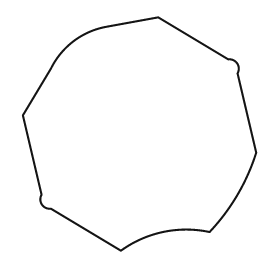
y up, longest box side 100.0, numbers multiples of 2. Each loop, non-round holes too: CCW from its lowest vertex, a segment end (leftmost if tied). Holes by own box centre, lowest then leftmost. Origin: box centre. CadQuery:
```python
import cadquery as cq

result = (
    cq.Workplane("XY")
    .moveTo(-8.0, -50.0)
    .threePointArc((10.0, -42.0), (30.0, -42.0))
    .threePointArc((42.0, -26.0), (50.0, -8.0))
    .lineTo(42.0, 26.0)
    .threePointArc((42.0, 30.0), (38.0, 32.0))
    .lineTo(8.0, 50.0)
    .lineTo(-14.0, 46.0)
    .threePointArc((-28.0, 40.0), (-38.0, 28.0))
    .lineTo(-50.0, 8.0)
    .lineTo(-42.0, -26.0)
    .threePointArc((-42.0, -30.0), (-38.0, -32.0))
    .close()
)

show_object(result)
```